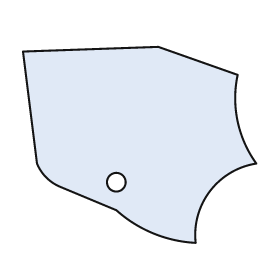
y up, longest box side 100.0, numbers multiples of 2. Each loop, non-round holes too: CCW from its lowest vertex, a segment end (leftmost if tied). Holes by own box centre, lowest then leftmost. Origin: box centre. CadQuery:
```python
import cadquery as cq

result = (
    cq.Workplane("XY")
    .moveTo(24.0, -42.0)
    .threePointArc((30.0, -20.0), (50.0, -8.0))
    .threePointArc((42.0, 10.0), (42.0, 30.0))
    .lineTo(8.0, 42.0)
    .lineTo(-50.0, 40.0)
    .lineTo(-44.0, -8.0)
    .threePointArc((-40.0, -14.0), (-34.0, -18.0))
    .lineTo(-10.0, -28.0)
    .threePointArc((6.0, -38.0), (24.0, -42.0))
    .close()
    .moveTo(-10.0, -16.0)
    .circle(4.0)
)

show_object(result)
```